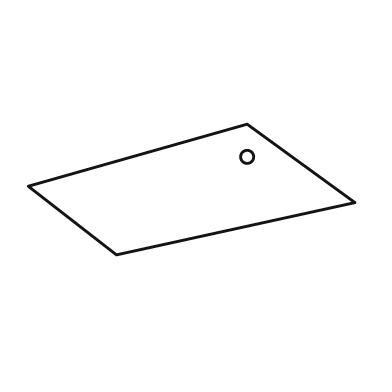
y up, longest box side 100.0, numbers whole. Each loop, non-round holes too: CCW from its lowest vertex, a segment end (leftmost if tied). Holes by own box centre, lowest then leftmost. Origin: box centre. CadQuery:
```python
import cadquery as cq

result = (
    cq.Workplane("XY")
    .moveTo(-23.0, -20.0)
    .lineTo(50.0, -4.0)
    .lineTo(17.0, 20.0)
    .lineTo(-50.0, 1.0)
    .close()
    .moveTo(17.0, 10.0)
    .circle(2.0)
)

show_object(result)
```